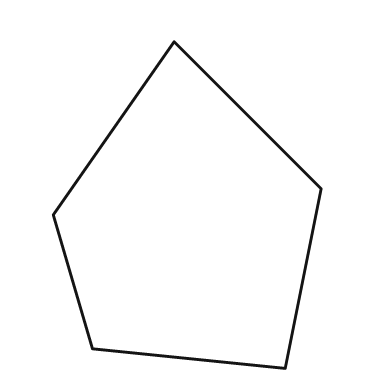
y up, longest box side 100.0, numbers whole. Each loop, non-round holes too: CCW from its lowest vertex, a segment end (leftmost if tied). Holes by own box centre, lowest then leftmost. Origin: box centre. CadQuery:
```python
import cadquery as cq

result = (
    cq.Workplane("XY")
    .moveTo(30.0, -50.0)
    .lineTo(41.0, 5.0)
    .lineTo(-4.0, 50.0)
    .lineTo(-41.0, -3.0)
    .lineTo(-29.0, -44.0)
    .close()
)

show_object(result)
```